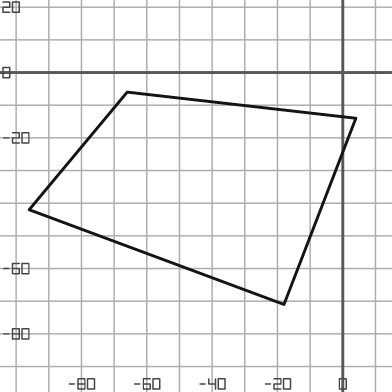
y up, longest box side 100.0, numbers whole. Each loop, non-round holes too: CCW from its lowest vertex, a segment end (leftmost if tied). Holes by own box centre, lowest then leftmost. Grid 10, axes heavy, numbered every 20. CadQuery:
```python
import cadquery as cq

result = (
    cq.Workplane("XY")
    .moveTo(-18.0, -71.0)
    .lineTo(4.0, -14.0)
    .lineTo(-66.0, -6.0)
    .lineTo(-96.0, -42.0)
    .close()
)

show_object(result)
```